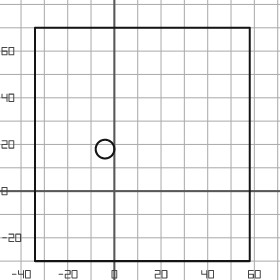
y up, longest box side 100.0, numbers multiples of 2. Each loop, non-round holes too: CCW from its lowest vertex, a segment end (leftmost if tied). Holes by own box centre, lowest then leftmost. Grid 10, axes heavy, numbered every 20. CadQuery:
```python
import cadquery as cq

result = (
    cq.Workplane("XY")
    .moveTo(-34.0, -30.0)
    .lineTo(58.0, -30.0)
    .lineTo(58.0, 70.0)
    .lineTo(-34.0, 70.0)
    .close()
    .moveTo(-4.0, 18.0)
    .circle(4.0)
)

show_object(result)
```